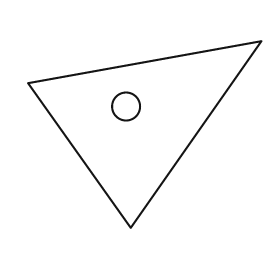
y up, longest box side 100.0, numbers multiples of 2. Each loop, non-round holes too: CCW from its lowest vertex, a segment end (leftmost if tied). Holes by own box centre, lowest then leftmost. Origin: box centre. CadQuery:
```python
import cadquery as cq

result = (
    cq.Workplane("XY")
    .moveTo(-6.0, -40.0)
    .lineTo(50.0, 40.0)
    .lineTo(-50.0, 22.0)
    .close()
    .moveTo(-8.0, 12.0)
    .circle(6.0)
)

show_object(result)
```